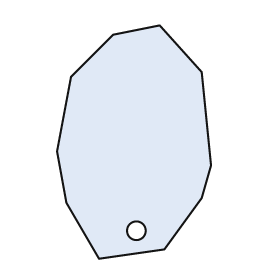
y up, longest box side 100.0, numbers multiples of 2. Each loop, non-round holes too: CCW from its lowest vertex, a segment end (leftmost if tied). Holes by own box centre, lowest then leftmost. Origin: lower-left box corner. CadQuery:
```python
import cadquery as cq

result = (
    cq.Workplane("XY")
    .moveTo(18.0, 0.0)
    .lineTo(46.0, 4.0)
    .lineTo(62.0, 26.0)
    .lineTo(66.0, 40.0)
    .lineTo(62.0, 80.0)
    .lineTo(44.0, 100.0)
    .lineTo(24.0, 96.0)
    .lineTo(6.0, 78.0)
    .lineTo(0.0, 46.0)
    .lineTo(4.0, 24.0)
    .close()
    .moveTo(34.0, 12.0)
    .circle(4.0)
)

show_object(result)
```